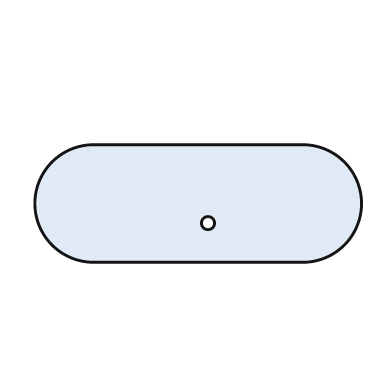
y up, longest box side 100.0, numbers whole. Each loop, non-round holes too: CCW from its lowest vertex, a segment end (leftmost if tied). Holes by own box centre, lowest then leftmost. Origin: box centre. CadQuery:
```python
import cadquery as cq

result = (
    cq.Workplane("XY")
    .moveTo(-32.0, -18.0)
    .lineTo(32.0, -18.0)
    .threePointArc((50.0, 0.0), (32.0, 18.0))
    .lineTo(-32.0, 18.0)
    .threePointArc((-50.0, 0.0), (-32.0, -18.0))
    .close()
    .moveTo(3.0, -6.0)
    .circle(2.0)
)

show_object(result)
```